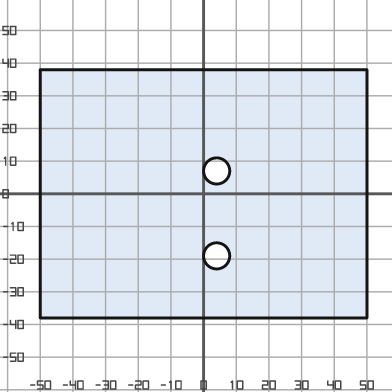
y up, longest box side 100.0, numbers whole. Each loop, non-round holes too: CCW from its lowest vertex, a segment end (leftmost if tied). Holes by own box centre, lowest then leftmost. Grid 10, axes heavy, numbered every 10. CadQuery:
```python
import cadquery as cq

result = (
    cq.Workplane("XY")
    .moveTo(-50.0, -38.0)
    .lineTo(50.0, -38.0)
    .lineTo(50.0, 38.0)
    .lineTo(-50.0, 38.0)
    .close()
    .moveTo(4.0, -19.0)
    .circle(4.0)
    .moveTo(4.0, 7.0)
    .circle(4.0)
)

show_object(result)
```